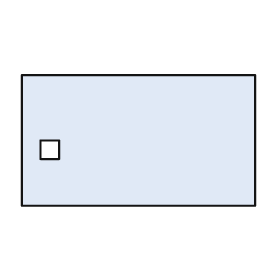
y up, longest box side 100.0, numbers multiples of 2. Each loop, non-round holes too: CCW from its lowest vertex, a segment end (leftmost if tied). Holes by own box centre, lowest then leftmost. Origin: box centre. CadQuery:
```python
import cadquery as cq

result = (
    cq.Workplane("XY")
    .moveTo(-50.0, -28.0)
    .lineTo(50.0, -28.0)
    .lineTo(50.0, 28.0)
    .lineTo(-50.0, 28.0)
    .close()
    .moveTo(-42.0, -8.0)
    .lineTo(-34.0, -8.0)
    .lineTo(-34.0, 0.0)
    .lineTo(-42.0, 0.0)
    .close()
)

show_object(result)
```